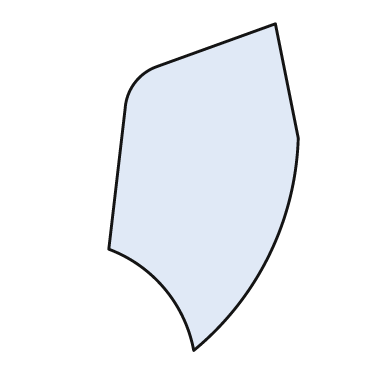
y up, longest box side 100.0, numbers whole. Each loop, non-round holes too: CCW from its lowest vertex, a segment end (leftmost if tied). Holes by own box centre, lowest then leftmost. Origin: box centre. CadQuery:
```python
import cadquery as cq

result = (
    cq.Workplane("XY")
    .moveTo(-3.0, -50.0)
    .threePointArc((20.0, -21.0), (29.0, 15.0))
    .lineTo(22.0, 50.0)
    .lineTo(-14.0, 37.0)
    .threePointArc((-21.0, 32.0), (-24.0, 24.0))
    .lineTo(-29.0, -19.0)
    .threePointArc((-12.0, -31.0), (-3.0, -50.0))
    .close()
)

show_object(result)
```